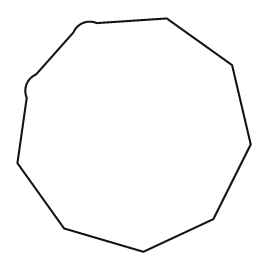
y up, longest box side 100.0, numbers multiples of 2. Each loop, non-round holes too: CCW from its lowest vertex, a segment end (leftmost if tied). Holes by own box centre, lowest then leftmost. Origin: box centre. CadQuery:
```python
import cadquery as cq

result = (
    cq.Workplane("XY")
    .moveTo(4.0, -50.0)
    .lineTo(34.0, -36.0)
    .lineTo(50.0, -4.0)
    .lineTo(42.0, 30.0)
    .lineTo(14.0, 50.0)
    .lineTo(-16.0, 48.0)
    .threePointArc((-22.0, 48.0), (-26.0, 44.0))
    .lineTo(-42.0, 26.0)
    .threePointArc((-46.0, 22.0), (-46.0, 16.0))
    .lineTo(-50.0, -12.0)
    .lineTo(-30.0, -40.0)
    .close()
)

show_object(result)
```